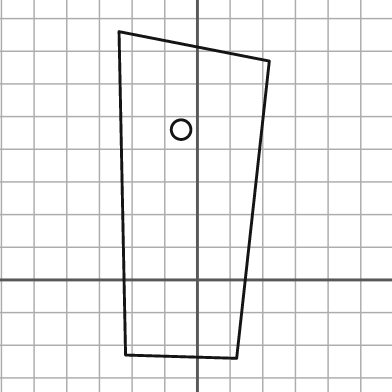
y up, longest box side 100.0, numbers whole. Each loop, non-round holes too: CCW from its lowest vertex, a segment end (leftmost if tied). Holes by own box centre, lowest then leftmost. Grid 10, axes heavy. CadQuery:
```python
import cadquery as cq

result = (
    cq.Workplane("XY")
    .moveTo(12.0, -24.0)
    .lineTo(22.0, 67.0)
    .lineTo(-24.0, 76.0)
    .lineTo(-22.0, -23.0)
    .close()
    .moveTo(-5.0, 46.0)
    .circle(3.0)
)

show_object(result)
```